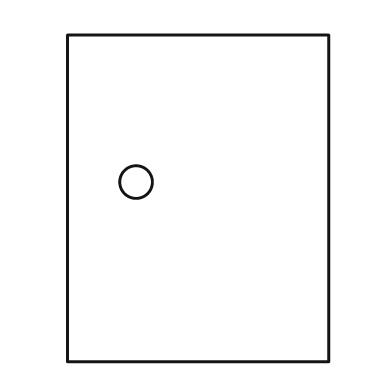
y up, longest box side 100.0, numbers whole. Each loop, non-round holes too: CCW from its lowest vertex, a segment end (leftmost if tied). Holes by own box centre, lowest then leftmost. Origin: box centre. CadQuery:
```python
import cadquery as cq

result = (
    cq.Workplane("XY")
    .moveTo(-40.0, -50.0)
    .lineTo(40.0, -50.0)
    .lineTo(40.0, 50.0)
    .lineTo(-40.0, 50.0)
    .close()
    .moveTo(-19.0, 5.0)
    .circle(5.0)
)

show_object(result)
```